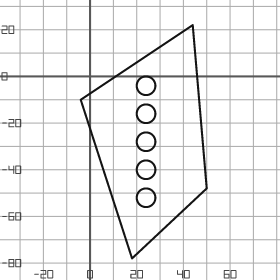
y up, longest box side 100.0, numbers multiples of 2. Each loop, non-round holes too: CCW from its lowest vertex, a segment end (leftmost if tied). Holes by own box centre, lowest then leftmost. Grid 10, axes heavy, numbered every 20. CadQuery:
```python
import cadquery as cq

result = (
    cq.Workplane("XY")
    .moveTo(18.0, -78.0)
    .lineTo(50.0, -48.0)
    .lineTo(44.0, 22.0)
    .lineTo(-4.0, -10.0)
    .close()
    .moveTo(24.0, -52.0)
    .circle(4.0)
    .moveTo(24.0, -40.0)
    .circle(4.0)
    .moveTo(24.0, -28.0)
    .circle(4.0)
    .moveTo(24.0, -16.0)
    .circle(4.0)
    .moveTo(24.0, -4.0)
    .circle(4.0)
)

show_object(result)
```